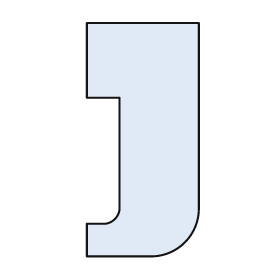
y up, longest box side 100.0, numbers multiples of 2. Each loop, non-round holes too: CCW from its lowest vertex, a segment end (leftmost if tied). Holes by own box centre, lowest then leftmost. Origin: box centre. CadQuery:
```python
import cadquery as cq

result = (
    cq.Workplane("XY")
    .moveTo(-24.0, -50.0)
    .lineTo(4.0, -50.0)
    .threePointArc((18.0, -44.0), (24.0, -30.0))
    .lineTo(24.0, 50.0)
    .lineTo(-24.0, 50.0)
    .lineTo(-24.0, 18.0)
    .lineTo(-10.0, 18.0)
    .lineTo(-10.0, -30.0)
    .threePointArc((-12.0, -34.0), (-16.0, -36.0))
    .lineTo(-24.0, -36.0)
    .close()
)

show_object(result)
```